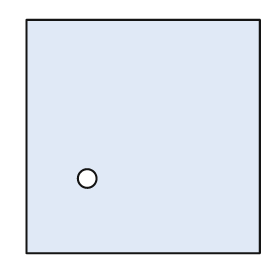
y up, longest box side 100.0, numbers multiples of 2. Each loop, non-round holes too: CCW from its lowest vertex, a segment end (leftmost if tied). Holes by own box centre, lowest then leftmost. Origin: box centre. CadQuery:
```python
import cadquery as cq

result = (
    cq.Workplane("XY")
    .moveTo(-50.0, -50.0)
    .lineTo(50.0, -50.0)
    .lineTo(50.0, 50.0)
    .lineTo(-50.0, 50.0)
    .close()
    .moveTo(-24.0, -18.0)
    .circle(4.0)
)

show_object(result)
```